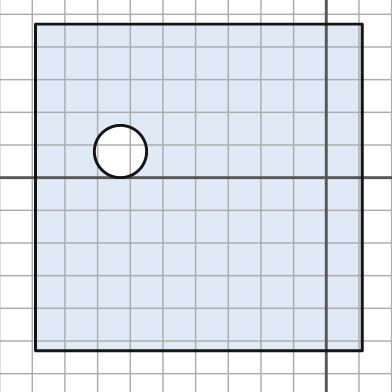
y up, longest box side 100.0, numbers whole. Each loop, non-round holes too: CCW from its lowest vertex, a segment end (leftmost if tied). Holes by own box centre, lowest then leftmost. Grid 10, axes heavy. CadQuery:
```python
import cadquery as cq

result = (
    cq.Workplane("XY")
    .moveTo(-89.0, -53.0)
    .lineTo(11.0, -53.0)
    .lineTo(11.0, 47.0)
    .lineTo(-89.0, 47.0)
    .close()
    .moveTo(-63.0, 8.0)
    .circle(8.0)
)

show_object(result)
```